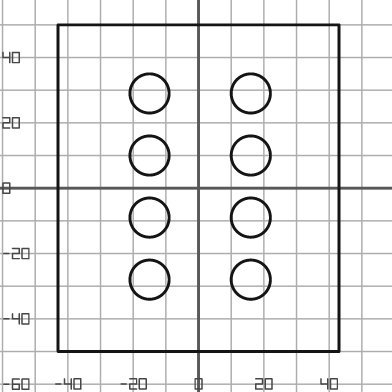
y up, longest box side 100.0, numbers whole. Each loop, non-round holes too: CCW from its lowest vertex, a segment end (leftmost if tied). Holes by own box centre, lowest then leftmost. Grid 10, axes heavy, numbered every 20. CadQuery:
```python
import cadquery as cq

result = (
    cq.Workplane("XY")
    .moveTo(-43.0, -50.0)
    .lineTo(43.0, -50.0)
    .lineTo(43.0, 50.0)
    .lineTo(-43.0, 50.0)
    .close()
    .moveTo(-15.0, -28.0)
    .circle(6.0)
    .moveTo(16.0, -28.0)
    .circle(6.0)
    .moveTo(-15.0, -9.0)
    .circle(6.0)
    .moveTo(16.0, -9.0)
    .circle(6.0)
    .moveTo(-15.0, 10.0)
    .circle(6.0)
    .moveTo(16.0, 10.0)
    .circle(6.0)
    .moveTo(-15.0, 29.0)
    .circle(6.0)
    .moveTo(16.0, 29.0)
    .circle(6.0)
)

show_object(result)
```